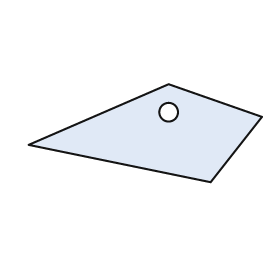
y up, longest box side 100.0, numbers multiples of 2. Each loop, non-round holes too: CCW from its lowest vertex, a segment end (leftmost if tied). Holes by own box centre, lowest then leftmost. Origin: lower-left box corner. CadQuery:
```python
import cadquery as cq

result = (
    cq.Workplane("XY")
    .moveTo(78.0, 0.0)
    .lineTo(100.0, 28.0)
    .lineTo(60.0, 42.0)
    .lineTo(0.0, 16.0)
    .close()
    .moveTo(60.0, 30.0)
    .circle(4.0)
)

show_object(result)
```